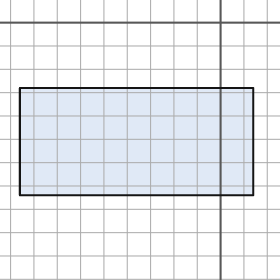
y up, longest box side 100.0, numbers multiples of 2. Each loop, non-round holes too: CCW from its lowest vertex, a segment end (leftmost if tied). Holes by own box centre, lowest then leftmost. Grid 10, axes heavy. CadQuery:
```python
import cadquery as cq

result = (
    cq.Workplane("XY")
    .moveTo(-86.0, -74.0)
    .lineTo(14.0, -74.0)
    .lineTo(14.0, -28.0)
    .lineTo(-86.0, -28.0)
    .close()
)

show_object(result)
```